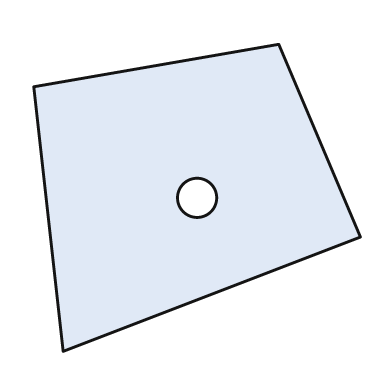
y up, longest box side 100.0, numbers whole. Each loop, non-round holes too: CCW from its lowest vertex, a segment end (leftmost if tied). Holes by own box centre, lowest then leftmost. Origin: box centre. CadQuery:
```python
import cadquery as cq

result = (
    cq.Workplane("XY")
    .moveTo(-41.0, -47.0)
    .lineTo(50.0, -12.0)
    .lineTo(25.0, 47.0)
    .lineTo(-50.0, 34.0)
    .close()
    .moveTo(0.0, 0.0)
    .circle(6.0)
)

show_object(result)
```